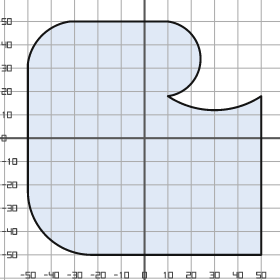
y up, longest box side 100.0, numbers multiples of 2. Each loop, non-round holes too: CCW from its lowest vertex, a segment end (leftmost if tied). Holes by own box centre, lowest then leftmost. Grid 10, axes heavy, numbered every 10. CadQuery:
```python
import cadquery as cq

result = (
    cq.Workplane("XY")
    .moveTo(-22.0, -50.0)
    .lineTo(50.0, -50.0)
    .lineTo(50.0, 18.0)
    .threePointArc((30.0, 12.0), (10.0, 18.0))
    .threePointArc((24.0, 34.0), (10.0, 50.0))
    .lineTo(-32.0, 50.0)
    .threePointArc((-44.0, 44.0), (-50.0, 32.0))
    .lineTo(-50.0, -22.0)
    .threePointArc((-42.0, -42.0), (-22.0, -50.0))
    .close()
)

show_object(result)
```